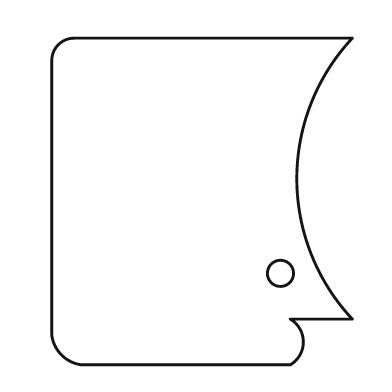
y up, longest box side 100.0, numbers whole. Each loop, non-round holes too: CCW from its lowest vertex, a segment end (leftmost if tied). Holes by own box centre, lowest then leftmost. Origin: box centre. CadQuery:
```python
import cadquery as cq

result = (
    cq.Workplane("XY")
    .moveTo(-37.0, -50.0)
    .lineTo(27.0, -50.0)
    .threePointArc((31.0, -43.0), (27.0, -36.0))
    .lineTo(46.0, -36.0)
    .threePointArc((29.0, 7.0), (46.0, 50.0))
    .lineTo(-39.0, 50.0)
    .threePointArc((-44.0, 48.0), (-46.0, 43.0))
    .lineTo(-46.0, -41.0)
    .threePointArc((-43.0, -47.0), (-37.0, -50.0))
    .close()
    .moveTo(24.0, -22.0)
    .circle(4.0)
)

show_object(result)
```